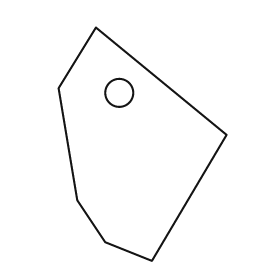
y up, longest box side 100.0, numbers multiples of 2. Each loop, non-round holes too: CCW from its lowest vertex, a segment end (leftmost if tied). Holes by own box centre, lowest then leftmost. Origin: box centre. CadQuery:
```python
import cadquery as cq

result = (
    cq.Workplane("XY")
    .moveTo(4.0, -50.0)
    .lineTo(36.0, 4.0)
    .lineTo(-20.0, 50.0)
    .lineTo(-36.0, 24.0)
    .lineTo(-28.0, -24.0)
    .lineTo(-16.0, -42.0)
    .close()
    .moveTo(-10.0, 22.0)
    .circle(6.0)
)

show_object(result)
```